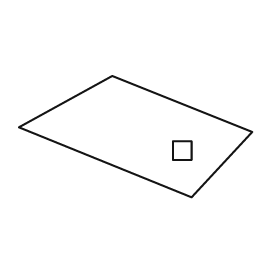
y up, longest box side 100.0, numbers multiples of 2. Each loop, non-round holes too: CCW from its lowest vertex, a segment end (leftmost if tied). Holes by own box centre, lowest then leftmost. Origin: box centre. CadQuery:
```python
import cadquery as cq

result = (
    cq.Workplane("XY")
    .moveTo(24.0, -26.0)
    .lineTo(50.0, 2.0)
    .lineTo(-10.0, 26.0)
    .lineTo(-50.0, 4.0)
    .close()
    .moveTo(16.0, -10.0)
    .lineTo(24.0, -10.0)
    .lineTo(24.0, -2.0)
    .lineTo(16.0, -2.0)
    .close()
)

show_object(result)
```